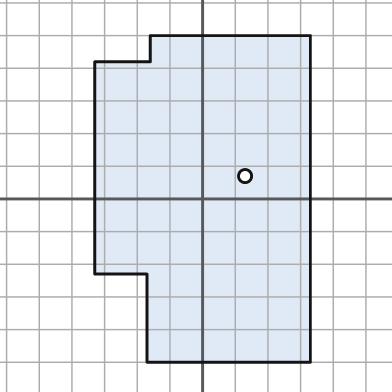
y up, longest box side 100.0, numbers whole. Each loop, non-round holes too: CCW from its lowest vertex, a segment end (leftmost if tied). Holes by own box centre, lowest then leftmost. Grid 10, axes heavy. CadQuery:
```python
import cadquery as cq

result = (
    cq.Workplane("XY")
    .moveTo(-17.0, -50.0)
    .lineTo(33.0, -50.0)
    .lineTo(33.0, 50.0)
    .lineTo(-16.0, 50.0)
    .lineTo(-16.0, 42.0)
    .lineTo(-33.0, 42.0)
    .lineTo(-33.0, -23.0)
    .lineTo(-17.0, -23.0)
    .close()
    .moveTo(13.0, 7.0)
    .circle(2.0)
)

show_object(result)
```